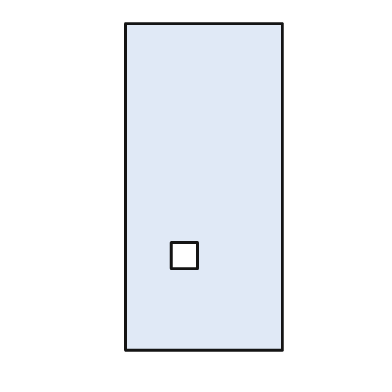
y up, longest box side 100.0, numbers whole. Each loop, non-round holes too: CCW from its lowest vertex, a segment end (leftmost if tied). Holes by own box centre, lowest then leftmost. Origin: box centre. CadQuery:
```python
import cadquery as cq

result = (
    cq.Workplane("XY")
    .moveTo(-24.0, -50.0)
    .lineTo(24.0, -50.0)
    .lineTo(24.0, 50.0)
    .lineTo(-24.0, 50.0)
    .close()
    .moveTo(-10.0, -25.0)
    .lineTo(-2.0, -25.0)
    .lineTo(-2.0, -17.0)
    .lineTo(-10.0, -17.0)
    .close()
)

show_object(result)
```